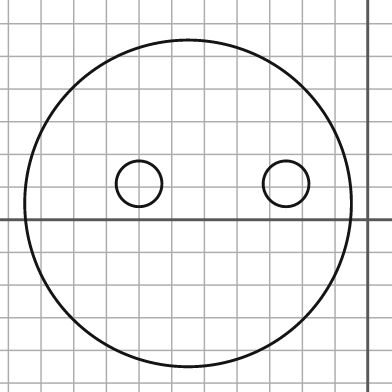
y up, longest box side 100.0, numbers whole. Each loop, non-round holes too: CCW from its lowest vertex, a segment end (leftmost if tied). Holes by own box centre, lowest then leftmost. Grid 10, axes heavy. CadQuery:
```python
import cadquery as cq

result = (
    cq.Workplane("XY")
    .moveTo(-55.0, 5.0)
    .circle(50.0)
    .moveTo(-70.0, 11.0)
    .circle(7.0)
    .moveTo(-25.0, 11.0)
    .circle(7.0)
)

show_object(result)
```